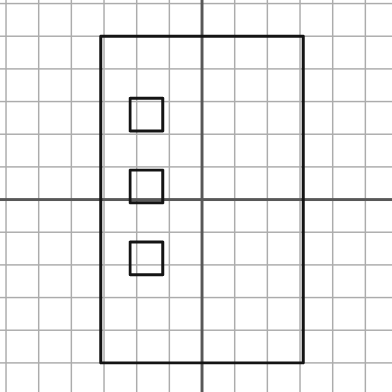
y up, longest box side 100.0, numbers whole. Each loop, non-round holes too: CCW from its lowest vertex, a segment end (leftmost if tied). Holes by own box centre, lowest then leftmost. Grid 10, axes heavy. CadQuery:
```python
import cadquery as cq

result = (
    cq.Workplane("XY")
    .moveTo(-31.0, -50.0)
    .lineTo(31.0, -50.0)
    .lineTo(31.0, 50.0)
    .lineTo(-31.0, 50.0)
    .close()
    .moveTo(-22.0, -23.0)
    .lineTo(-12.0, -23.0)
    .lineTo(-12.0, -13.0)
    .lineTo(-22.0, -13.0)
    .close()
    .moveTo(-22.0, -1.0)
    .lineTo(-12.0, -1.0)
    .lineTo(-12.0, 9.0)
    .lineTo(-22.0, 9.0)
    .close()
    .moveTo(-22.0, 21.0)
    .lineTo(-12.0, 21.0)
    .lineTo(-12.0, 31.0)
    .lineTo(-22.0, 31.0)
    .close()
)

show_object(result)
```